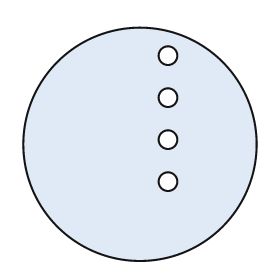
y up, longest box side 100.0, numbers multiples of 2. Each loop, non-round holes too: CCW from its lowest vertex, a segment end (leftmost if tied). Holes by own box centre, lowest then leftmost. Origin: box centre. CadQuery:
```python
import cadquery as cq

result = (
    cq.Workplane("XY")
    .moveTo(0.0, 0.0)
    .circle(50.0)
    .moveTo(12.0, -16.0)
    .circle(4.0)
    .moveTo(12.0, 2.0)
    .circle(4.0)
    .moveTo(12.0, 20.0)
    .circle(4.0)
    .moveTo(12.0, 38.0)
    .circle(4.0)
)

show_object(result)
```